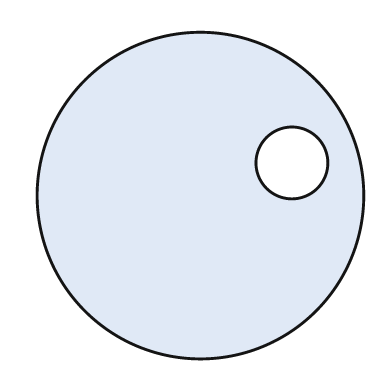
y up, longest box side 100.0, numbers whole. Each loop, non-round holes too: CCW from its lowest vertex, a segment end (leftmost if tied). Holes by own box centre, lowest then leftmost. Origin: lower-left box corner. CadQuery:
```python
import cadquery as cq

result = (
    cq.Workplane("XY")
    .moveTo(50.0, 50.0)
    .circle(50.0)
    .moveTo(78.0, 60.0)
    .circle(11.0)
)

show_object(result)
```